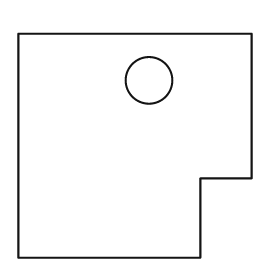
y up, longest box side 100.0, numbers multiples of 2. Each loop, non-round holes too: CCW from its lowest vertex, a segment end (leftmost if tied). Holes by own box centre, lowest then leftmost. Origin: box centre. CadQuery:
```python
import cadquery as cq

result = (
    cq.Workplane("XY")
    .moveTo(-50.0, -48.0)
    .lineTo(28.0, -48.0)
    .lineTo(28.0, -14.0)
    .lineTo(50.0, -14.0)
    .lineTo(50.0, 48.0)
    .lineTo(-50.0, 48.0)
    .close()
    .moveTo(6.0, 28.0)
    .circle(10.0)
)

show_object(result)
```